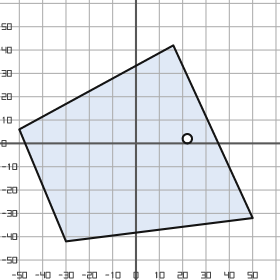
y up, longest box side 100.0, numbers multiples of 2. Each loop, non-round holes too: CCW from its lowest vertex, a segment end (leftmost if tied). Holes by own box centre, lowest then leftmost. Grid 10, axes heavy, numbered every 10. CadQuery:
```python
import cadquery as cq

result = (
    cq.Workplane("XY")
    .moveTo(-30.0, -42.0)
    .lineTo(50.0, -32.0)
    .lineTo(16.0, 42.0)
    .lineTo(-50.0, 6.0)
    .close()
    .moveTo(22.0, 2.0)
    .circle(2.0)
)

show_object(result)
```